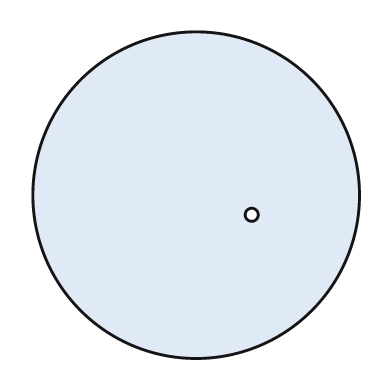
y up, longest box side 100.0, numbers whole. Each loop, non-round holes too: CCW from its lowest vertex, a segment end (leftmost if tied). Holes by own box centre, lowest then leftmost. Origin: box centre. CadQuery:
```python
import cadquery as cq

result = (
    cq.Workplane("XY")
    .moveTo(0.0, 0.0)
    .circle(50.0)
    .moveTo(17.0, -6.0)
    .circle(2.0)
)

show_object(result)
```